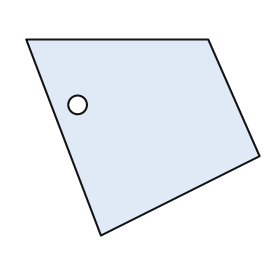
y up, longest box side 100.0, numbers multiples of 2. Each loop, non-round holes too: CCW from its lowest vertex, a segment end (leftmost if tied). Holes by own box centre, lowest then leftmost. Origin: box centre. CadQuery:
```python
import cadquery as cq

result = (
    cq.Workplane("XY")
    .moveTo(-18.0, -42.0)
    .lineTo(50.0, -8.0)
    .lineTo(28.0, 42.0)
    .lineTo(-50.0, 42.0)
    .close()
    .moveTo(-28.0, 14.0)
    .circle(4.0)
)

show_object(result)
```